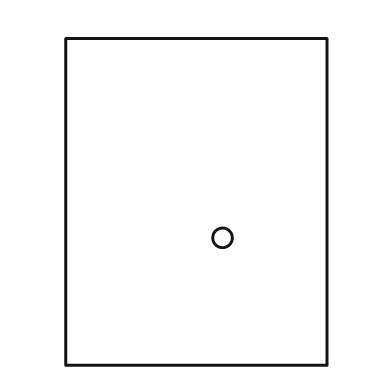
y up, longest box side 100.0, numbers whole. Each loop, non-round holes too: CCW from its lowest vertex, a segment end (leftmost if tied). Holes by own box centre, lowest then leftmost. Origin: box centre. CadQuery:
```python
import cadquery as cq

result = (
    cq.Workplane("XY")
    .moveTo(-40.0, -50.0)
    .lineTo(40.0, -50.0)
    .lineTo(40.0, 50.0)
    .lineTo(-40.0, 50.0)
    .close()
    .moveTo(8.0, -11.0)
    .circle(3.0)
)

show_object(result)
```